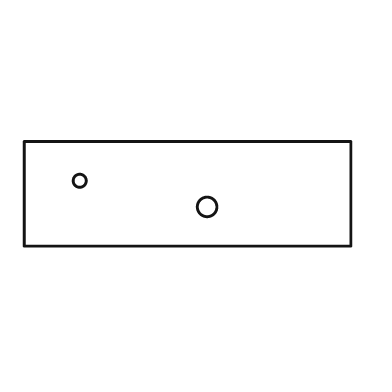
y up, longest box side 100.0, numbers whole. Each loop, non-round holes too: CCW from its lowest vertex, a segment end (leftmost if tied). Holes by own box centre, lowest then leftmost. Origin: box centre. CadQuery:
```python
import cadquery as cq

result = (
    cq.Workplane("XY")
    .moveTo(-50.0, -16.0)
    .lineTo(50.0, -16.0)
    .lineTo(50.0, 16.0)
    .lineTo(-50.0, 16.0)
    .close()
    .moveTo(6.0, -4.0)
    .circle(3.0)
    .moveTo(-33.0, 4.0)
    .circle(2.0)
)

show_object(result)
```